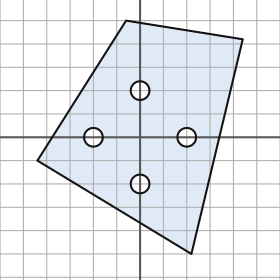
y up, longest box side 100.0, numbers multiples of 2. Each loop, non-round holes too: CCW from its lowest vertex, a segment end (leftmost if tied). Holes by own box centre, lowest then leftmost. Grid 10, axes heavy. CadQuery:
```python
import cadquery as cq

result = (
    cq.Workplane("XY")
    .moveTo(22.0, -50.0)
    .lineTo(44.0, 42.0)
    .lineTo(-6.0, 50.0)
    .lineTo(-44.0, -10.0)
    .close()
    .moveTo(0.0, -20.0)
    .circle(4.0)
    .moveTo(-20.0, 0.0)
    .circle(4.0)
    .moveTo(20.0, 0.0)
    .circle(4.0)
    .moveTo(0.0, 20.0)
    .circle(4.0)
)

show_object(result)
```